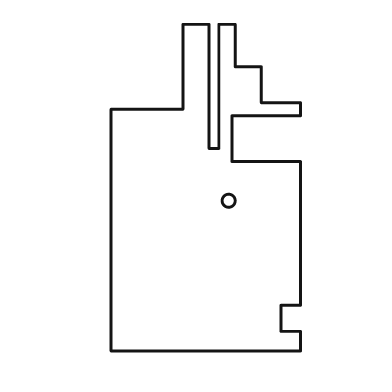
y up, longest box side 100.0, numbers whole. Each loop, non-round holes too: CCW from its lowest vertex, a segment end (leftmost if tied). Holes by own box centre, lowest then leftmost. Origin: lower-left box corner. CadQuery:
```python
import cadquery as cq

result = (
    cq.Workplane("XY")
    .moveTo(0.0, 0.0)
    .lineTo(58.0, 0.0)
    .lineTo(58.0, 6.0)
    .lineTo(52.0, 6.0)
    .lineTo(52.0, 14.0)
    .lineTo(58.0, 14.0)
    .lineTo(58.0, 58.0)
    .lineTo(37.0, 58.0)
    .lineTo(37.0, 72.0)
    .lineTo(58.0, 72.0)
    .lineTo(58.0, 76.0)
    .lineTo(46.0, 76.0)
    .lineTo(46.0, 87.0)
    .lineTo(38.0, 87.0)
    .lineTo(38.0, 100.0)
    .lineTo(33.0, 100.0)
    .lineTo(33.0, 62.0)
    .lineTo(30.0, 62.0)
    .lineTo(30.0, 100.0)
    .lineTo(22.0, 100.0)
    .lineTo(22.0, 74.0)
    .lineTo(0.0, 74.0)
    .close()
    .moveTo(36.0, 46.0)
    .circle(2.0)
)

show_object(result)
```